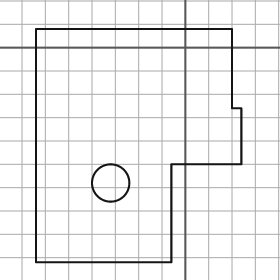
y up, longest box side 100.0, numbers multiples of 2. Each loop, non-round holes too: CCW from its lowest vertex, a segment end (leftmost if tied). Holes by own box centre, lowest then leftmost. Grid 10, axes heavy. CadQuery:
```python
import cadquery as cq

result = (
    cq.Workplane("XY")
    .moveTo(-64.0, -92.0)
    .lineTo(-6.0, -92.0)
    .lineTo(-6.0, -50.0)
    .lineTo(24.0, -50.0)
    .lineTo(24.0, -26.0)
    .lineTo(20.0, -26.0)
    .lineTo(20.0, 8.0)
    .lineTo(-64.0, 8.0)
    .close()
    .moveTo(-32.0, -58.0)
    .circle(8.0)
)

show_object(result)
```